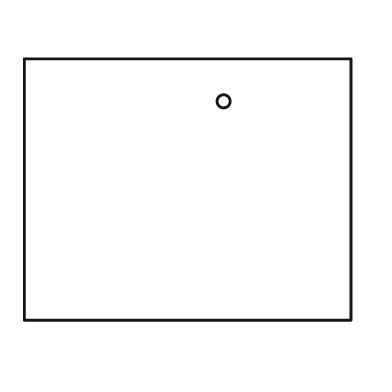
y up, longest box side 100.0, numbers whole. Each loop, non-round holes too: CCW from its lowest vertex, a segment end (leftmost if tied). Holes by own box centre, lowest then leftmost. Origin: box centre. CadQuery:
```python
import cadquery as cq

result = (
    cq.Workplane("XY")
    .moveTo(-50.0, -40.0)
    .lineTo(50.0, -40.0)
    .lineTo(50.0, 40.0)
    .lineTo(-50.0, 40.0)
    .close()
    .moveTo(11.0, 27.0)
    .circle(2.0)
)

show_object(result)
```